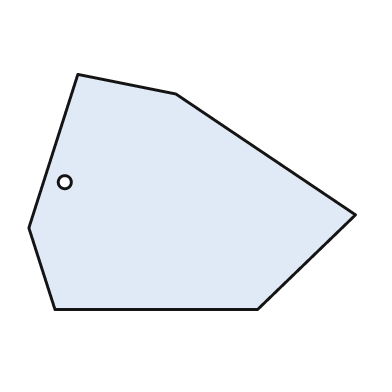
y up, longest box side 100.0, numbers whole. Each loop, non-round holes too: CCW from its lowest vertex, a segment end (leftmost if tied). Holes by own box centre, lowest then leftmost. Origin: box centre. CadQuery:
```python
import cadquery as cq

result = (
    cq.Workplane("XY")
    .moveTo(-42.0, -36.0)
    .lineTo(20.0, -36.0)
    .lineTo(50.0, -7.0)
    .lineTo(-5.0, 30.0)
    .lineTo(-35.0, 36.0)
    .lineTo(-50.0, -11.0)
    .close()
    .moveTo(-39.0, 3.0)
    .circle(2.0)
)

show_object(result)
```